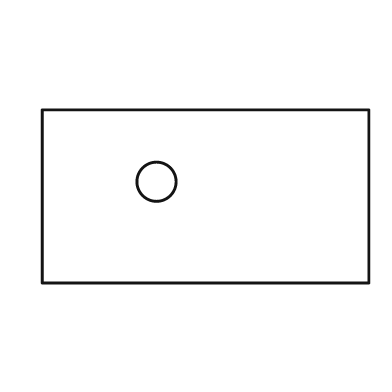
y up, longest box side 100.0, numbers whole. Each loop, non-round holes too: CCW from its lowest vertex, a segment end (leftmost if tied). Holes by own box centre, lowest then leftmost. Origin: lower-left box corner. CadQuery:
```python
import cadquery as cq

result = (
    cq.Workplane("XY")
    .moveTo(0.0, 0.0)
    .lineTo(100.0, 0.0)
    .lineTo(100.0, 53.0)
    .lineTo(0.0, 53.0)
    .close()
    .moveTo(35.0, 31.0)
    .circle(6.0)
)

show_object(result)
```